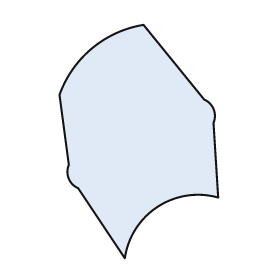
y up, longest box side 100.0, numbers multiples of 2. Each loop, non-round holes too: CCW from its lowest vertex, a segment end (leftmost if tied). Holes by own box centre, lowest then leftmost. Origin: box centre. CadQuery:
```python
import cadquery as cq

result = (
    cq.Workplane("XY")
    .moveTo(-6.0, -50.0)
    .threePointArc((8.0, -28.0), (34.0, -24.0))
    .lineTo(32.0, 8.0)
    .threePointArc((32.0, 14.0), (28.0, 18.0))
    .lineTo(2.0, 50.0)
    .threePointArc((-20.0, 40.0), (-34.0, 20.0))
    .lineTo(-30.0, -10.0)
    .threePointArc((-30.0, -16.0), (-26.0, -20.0))
    .close()
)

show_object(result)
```